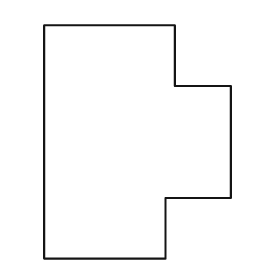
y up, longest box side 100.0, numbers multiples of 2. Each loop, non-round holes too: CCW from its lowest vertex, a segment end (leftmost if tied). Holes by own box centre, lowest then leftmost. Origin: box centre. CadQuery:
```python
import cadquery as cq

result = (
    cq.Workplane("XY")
    .moveTo(-40.0, -50.0)
    .lineTo(12.0, -50.0)
    .lineTo(12.0, -24.0)
    .lineTo(40.0, -24.0)
    .lineTo(40.0, 24.0)
    .lineTo(16.0, 24.0)
    .lineTo(16.0, 50.0)
    .lineTo(-40.0, 50.0)
    .close()
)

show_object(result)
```